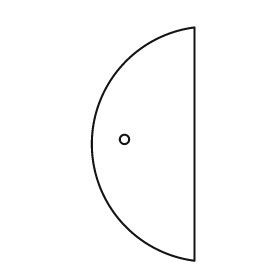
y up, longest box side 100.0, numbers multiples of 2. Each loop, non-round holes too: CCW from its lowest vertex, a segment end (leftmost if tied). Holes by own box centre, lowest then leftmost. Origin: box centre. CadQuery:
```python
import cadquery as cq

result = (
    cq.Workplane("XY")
    .moveTo(22.0, -50.0)
    .lineTo(22.0, 50.0)
    .threePointArc((-22.0, 0.0), (22.0, -50.0))
    .close()
    .moveTo(-8.0, 2.0)
    .circle(2.0)
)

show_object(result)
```